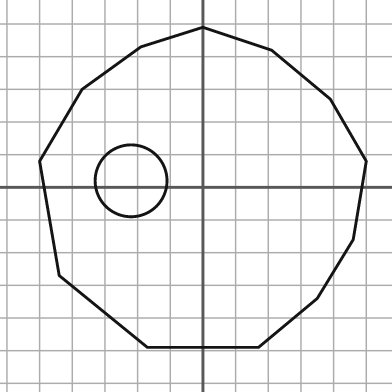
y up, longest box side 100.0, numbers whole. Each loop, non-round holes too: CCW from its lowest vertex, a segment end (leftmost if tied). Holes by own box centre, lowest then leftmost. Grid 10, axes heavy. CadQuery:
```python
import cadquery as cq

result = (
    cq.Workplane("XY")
    .moveTo(-17.0, -49.0)
    .lineTo(17.0, -49.0)
    .lineTo(35.0, -34.0)
    .lineTo(46.0, -16.0)
    .lineTo(50.0, 8.0)
    .lineTo(39.0, 27.0)
    .lineTo(21.0, 42.0)
    .lineTo(0.0, 49.0)
    .lineTo(-19.0, 43.0)
    .lineTo(-37.0, 30.0)
    .lineTo(-50.0, 8.0)
    .lineTo(-44.0, -27.0)
    .close()
    .moveTo(-22.0, 2.0)
    .circle(11.0)
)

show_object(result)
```